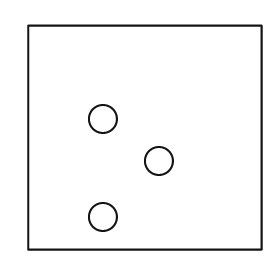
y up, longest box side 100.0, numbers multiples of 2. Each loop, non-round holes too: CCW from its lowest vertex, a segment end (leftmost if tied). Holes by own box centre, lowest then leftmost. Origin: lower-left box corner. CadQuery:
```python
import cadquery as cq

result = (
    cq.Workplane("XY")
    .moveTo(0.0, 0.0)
    .lineTo(100.0, 0.0)
    .lineTo(100.0, 96.0)
    .lineTo(0.0, 96.0)
    .close()
    .moveTo(32.0, 14.0)
    .circle(6.0)
    .moveTo(56.0, 38.0)
    .circle(6.0)
    .moveTo(32.0, 56.0)
    .circle(6.0)
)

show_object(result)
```